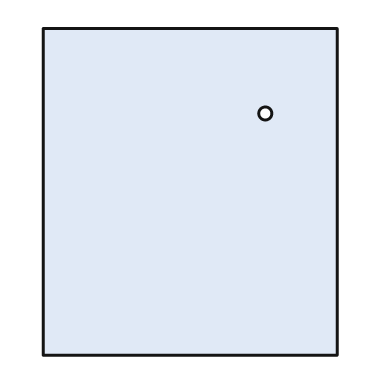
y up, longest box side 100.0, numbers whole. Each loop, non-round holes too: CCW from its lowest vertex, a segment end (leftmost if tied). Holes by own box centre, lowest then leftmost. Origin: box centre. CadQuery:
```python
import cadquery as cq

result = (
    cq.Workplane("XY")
    .moveTo(-45.0, -50.0)
    .lineTo(45.0, -50.0)
    .lineTo(45.0, 50.0)
    .lineTo(-45.0, 50.0)
    .close()
    .moveTo(23.0, 24.0)
    .circle(2.0)
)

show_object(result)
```